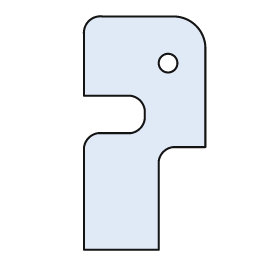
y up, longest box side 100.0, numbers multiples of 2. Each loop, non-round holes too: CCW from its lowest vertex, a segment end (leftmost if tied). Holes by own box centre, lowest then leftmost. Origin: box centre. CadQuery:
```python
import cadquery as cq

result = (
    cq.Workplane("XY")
    .moveTo(-26.0, -50.0)
    .lineTo(6.0, -50.0)
    .lineTo(6.0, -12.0)
    .threePointArc((8.0, -8.0), (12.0, -6.0))
    .lineTo(26.0, -6.0)
    .lineTo(26.0, 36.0)
    .threePointArc((22.0, 46.0), (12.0, 50.0))
    .lineTo(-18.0, 50.0)
    .threePointArc((-24.0, 48.0), (-26.0, 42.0))
    .lineTo(-26.0, 16.0)
    .lineTo(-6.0, 16.0)
    .threePointArc((-2.0, 14.0), (0.0, 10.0))
    .lineTo(0.0, 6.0)
    .threePointArc((-2.0, 2.0), (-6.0, 0.0))
    .lineTo(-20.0, 0.0)
    .threePointArc((-24.0, -2.0), (-26.0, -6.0))
    .close()
    .moveTo(10.0, 30.0)
    .circle(4.0)
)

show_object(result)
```